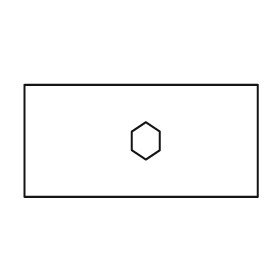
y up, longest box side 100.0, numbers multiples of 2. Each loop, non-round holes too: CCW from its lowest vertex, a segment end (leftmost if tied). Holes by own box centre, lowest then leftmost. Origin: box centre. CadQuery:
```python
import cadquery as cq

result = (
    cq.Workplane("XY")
    .moveTo(-50.0, -24.0)
    .lineTo(50.0, -24.0)
    .lineTo(50.0, 24.0)
    .lineTo(-50.0, 24.0)
    .close()
    .moveTo(2.0, -8.0)
    .lineTo(8.0, -4.0)
    .lineTo(8.0, 4.0)
    .lineTo(2.0, 8.0)
    .lineTo(-4.0, 4.0)
    .lineTo(-4.0, -4.0)
    .close()
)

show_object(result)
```